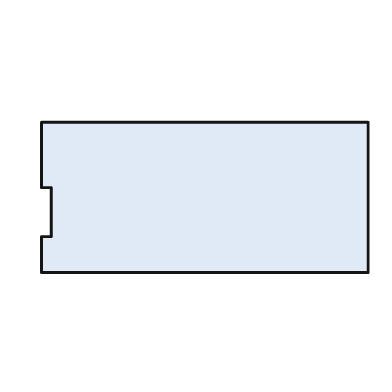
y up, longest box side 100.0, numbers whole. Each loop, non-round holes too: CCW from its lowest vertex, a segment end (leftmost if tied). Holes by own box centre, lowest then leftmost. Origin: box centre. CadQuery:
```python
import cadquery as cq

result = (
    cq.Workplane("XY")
    .moveTo(-50.0, -23.0)
    .lineTo(50.0, -23.0)
    .lineTo(50.0, 23.0)
    .lineTo(-50.0, 23.0)
    .lineTo(-50.0, 3.0)
    .lineTo(-47.0, 3.0)
    .lineTo(-47.0, -12.0)
    .lineTo(-50.0, -12.0)
    .close()
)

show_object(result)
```